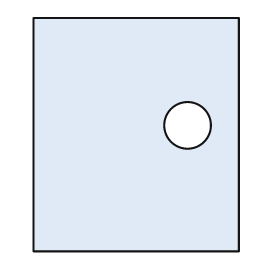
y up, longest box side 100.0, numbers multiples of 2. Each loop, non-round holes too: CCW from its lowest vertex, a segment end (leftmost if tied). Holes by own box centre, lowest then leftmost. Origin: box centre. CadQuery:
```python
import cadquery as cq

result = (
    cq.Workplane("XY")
    .moveTo(-44.0, -50.0)
    .lineTo(44.0, -50.0)
    .lineTo(44.0, 50.0)
    .lineTo(-44.0, 50.0)
    .close()
    .moveTo(22.0, 4.0)
    .circle(10.0)
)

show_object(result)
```